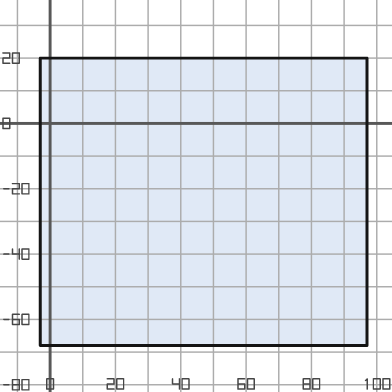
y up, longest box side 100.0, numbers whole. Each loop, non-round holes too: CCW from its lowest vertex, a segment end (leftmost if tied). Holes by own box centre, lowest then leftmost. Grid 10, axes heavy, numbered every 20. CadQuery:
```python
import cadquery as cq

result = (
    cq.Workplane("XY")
    .moveTo(-3.0, -68.0)
    .lineTo(97.0, -68.0)
    .lineTo(97.0, 20.0)
    .lineTo(-3.0, 20.0)
    .close()
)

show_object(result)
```